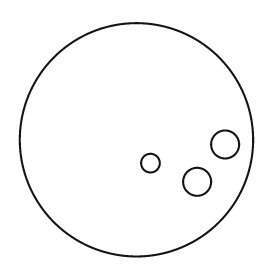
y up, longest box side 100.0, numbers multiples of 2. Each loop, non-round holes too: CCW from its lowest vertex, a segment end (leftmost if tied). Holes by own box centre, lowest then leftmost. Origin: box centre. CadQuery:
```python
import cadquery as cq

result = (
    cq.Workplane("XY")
    .moveTo(0.0, 0.0)
    .circle(50.0)
    .moveTo(26.0, -18.0)
    .circle(6.0)
    .moveTo(6.0, -10.0)
    .circle(4.0)
    .moveTo(38.0, -2.0)
    .circle(6.0)
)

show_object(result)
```